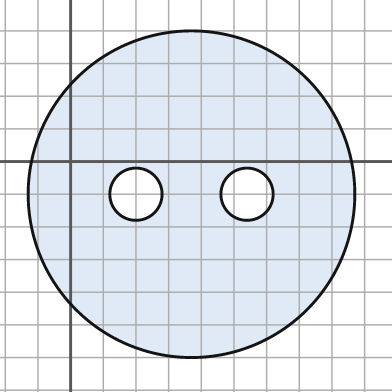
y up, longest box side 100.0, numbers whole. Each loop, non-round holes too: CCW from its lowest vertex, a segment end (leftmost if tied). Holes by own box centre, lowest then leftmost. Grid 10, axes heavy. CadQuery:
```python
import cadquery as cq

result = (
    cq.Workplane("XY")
    .moveTo(37.0, -10.0)
    .circle(50.0)
    .moveTo(20.0, -10.0)
    .circle(8.0)
    .moveTo(54.0, -10.0)
    .circle(8.0)
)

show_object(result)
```